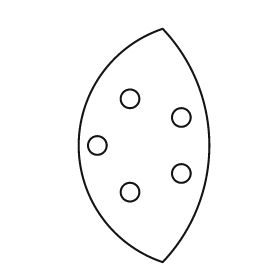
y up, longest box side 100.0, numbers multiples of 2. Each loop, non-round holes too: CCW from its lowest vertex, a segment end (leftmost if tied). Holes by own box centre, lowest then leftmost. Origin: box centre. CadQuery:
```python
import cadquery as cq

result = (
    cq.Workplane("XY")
    .moveTo(8.0, -50.0)
    .threePointArc((28.0, 0.0), (8.0, 50.0))
    .threePointArc((-28.0, 0.0), (8.0, -50.0))
    .close()
    .moveTo(-6.0, -20.0)
    .circle(4.0)
    .moveTo(16.0, -12.0)
    .circle(4.0)
    .moveTo(-20.0, 0.0)
    .circle(4.0)
    .moveTo(16.0, 12.0)
    .circle(4.0)
    .moveTo(-6.0, 20.0)
    .circle(4.0)
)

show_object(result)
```